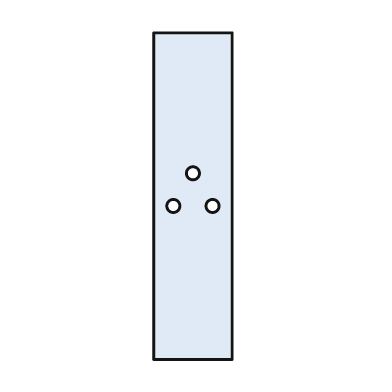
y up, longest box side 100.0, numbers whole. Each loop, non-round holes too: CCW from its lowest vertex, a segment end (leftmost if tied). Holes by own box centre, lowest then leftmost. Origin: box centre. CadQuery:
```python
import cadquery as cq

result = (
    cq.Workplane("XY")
    .moveTo(-12.0, -50.0)
    .lineTo(12.0, -50.0)
    .lineTo(12.0, 50.0)
    .lineTo(-12.0, 50.0)
    .close()
    .moveTo(-6.0, -3.0)
    .circle(2.0)
    .moveTo(6.0, -3.0)
    .circle(2.0)
    .moveTo(0.0, 7.0)
    .circle(2.0)
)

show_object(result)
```